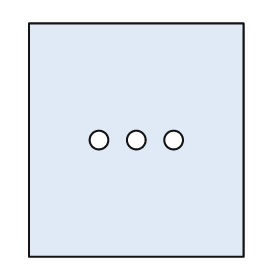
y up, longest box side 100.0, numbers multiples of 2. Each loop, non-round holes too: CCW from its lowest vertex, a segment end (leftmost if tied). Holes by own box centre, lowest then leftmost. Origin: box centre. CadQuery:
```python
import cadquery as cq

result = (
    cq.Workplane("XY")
    .moveTo(-46.0, -50.0)
    .lineTo(46.0, -50.0)
    .lineTo(46.0, 50.0)
    .lineTo(-46.0, 50.0)
    .close()
    .moveTo(-16.0, 0.0)
    .circle(4.0)
    .moveTo(0.0, 0.0)
    .circle(4.0)
    .moveTo(16.0, 0.0)
    .circle(4.0)
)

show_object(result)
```